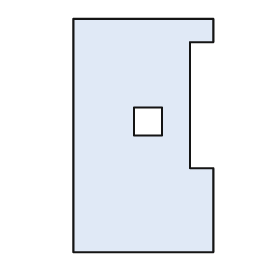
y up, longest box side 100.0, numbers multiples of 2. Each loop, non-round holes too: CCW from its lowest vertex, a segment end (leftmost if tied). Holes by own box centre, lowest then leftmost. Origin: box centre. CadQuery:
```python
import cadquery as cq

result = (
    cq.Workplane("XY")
    .moveTo(-30.0, -50.0)
    .lineTo(30.0, -50.0)
    .lineTo(30.0, -14.0)
    .lineTo(20.0, -14.0)
    .lineTo(20.0, 40.0)
    .lineTo(30.0, 40.0)
    .lineTo(30.0, 50.0)
    .lineTo(-30.0, 50.0)
    .close()
    .moveTo(-4.0, 0.0)
    .lineTo(8.0, 0.0)
    .lineTo(8.0, 12.0)
    .lineTo(-4.0, 12.0)
    .close()
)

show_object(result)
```